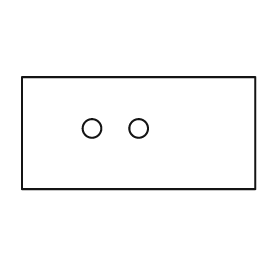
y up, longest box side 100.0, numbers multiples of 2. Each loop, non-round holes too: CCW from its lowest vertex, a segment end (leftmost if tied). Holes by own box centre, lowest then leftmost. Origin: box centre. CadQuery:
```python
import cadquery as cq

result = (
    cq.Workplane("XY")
    .moveTo(-50.0, -24.0)
    .lineTo(50.0, -24.0)
    .lineTo(50.0, 24.0)
    .lineTo(-50.0, 24.0)
    .close()
    .moveTo(-20.0, 2.0)
    .circle(4.0)
    .moveTo(0.0, 2.0)
    .circle(4.0)
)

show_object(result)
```